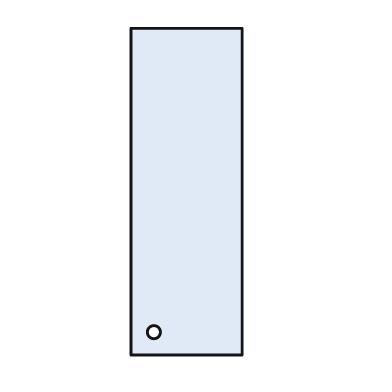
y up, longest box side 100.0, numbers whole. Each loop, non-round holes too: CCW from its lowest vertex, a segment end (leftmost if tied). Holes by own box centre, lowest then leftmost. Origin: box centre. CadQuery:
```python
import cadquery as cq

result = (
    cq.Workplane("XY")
    .moveTo(-17.0, -50.0)
    .lineTo(17.0, -50.0)
    .lineTo(17.0, 50.0)
    .lineTo(-17.0, 50.0)
    .close()
    .moveTo(-10.0, -43.0)
    .circle(2.0)
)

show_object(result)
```